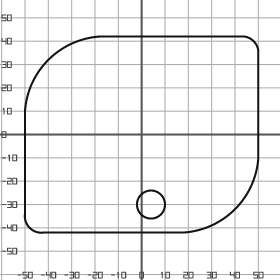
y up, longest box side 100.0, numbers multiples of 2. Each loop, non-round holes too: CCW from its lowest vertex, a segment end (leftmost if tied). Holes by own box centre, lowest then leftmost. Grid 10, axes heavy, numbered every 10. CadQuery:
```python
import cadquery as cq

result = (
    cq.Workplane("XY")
    .moveTo(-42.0, -42.0)
    .lineTo(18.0, -42.0)
    .threePointArc((40.0, -32.0), (50.0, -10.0))
    .lineTo(50.0, 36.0)
    .threePointArc((48.0, 40.0), (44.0, 42.0))
    .lineTo(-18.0, 42.0)
    .threePointArc((-40.0, 32.0), (-50.0, 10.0))
    .lineTo(-50.0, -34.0)
    .threePointArc((-48.0, -40.0), (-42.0, -42.0))
    .close()
    .moveTo(4.0, -30.0)
    .circle(6.0)
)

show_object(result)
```